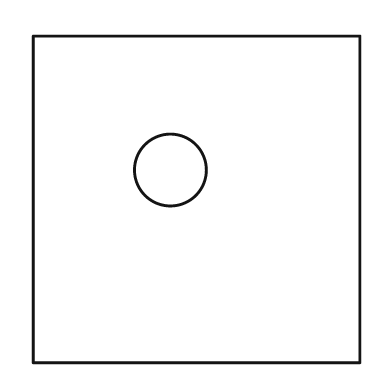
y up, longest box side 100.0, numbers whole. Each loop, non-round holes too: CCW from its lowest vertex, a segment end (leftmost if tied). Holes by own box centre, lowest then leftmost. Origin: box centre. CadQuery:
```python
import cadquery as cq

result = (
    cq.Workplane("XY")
    .moveTo(-50.0, -50.0)
    .lineTo(50.0, -50.0)
    .lineTo(50.0, 50.0)
    .lineTo(-50.0, 50.0)
    .close()
    .moveTo(-8.0, 9.0)
    .circle(11.0)
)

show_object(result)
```